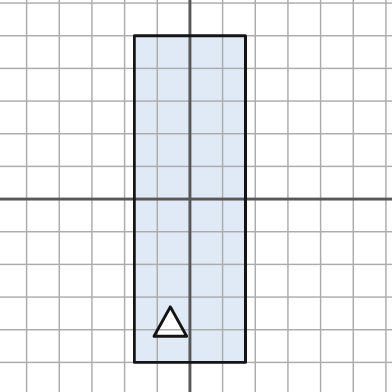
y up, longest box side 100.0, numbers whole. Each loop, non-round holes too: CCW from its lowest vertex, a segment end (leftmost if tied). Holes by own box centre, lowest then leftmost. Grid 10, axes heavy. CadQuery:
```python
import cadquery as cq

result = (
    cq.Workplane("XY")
    .moveTo(-17.0, -50.0)
    .lineTo(17.0, -50.0)
    .lineTo(17.0, 50.0)
    .lineTo(-17.0, 50.0)
    .close()
    .moveTo(-11.0, -42.0)
    .lineTo(-1.0, -42.0)
    .lineTo(-6.0, -33.0)
    .close()
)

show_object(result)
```